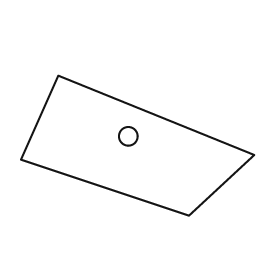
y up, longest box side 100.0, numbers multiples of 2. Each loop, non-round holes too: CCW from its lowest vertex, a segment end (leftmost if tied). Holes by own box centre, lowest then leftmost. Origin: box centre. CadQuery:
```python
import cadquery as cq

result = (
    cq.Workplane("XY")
    .moveTo(22.0, -30.0)
    .lineTo(50.0, -4.0)
    .lineTo(-34.0, 30.0)
    .lineTo(-50.0, -6.0)
    .close()
    .moveTo(-4.0, 4.0)
    .circle(4.0)
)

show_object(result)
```